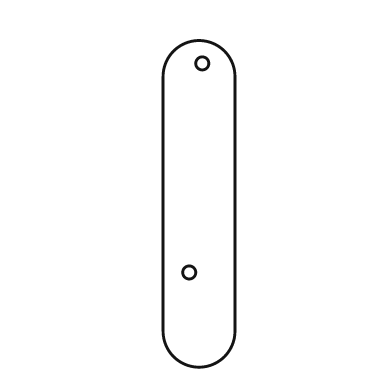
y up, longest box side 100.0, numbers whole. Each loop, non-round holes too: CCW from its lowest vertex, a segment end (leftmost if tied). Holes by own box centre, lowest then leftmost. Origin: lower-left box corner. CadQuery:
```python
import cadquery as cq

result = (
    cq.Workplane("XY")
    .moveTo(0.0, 11.0)
    .threePointArc((11.0, 0.0), (22.0, 11.0))
    .lineTo(22.0, 89.0)
    .threePointArc((11.0, 100.0), (0.0, 89.0))
    .close()
    .moveTo(8.0, 29.0)
    .circle(2.0)
    .moveTo(12.0, 93.0)
    .circle(2.0)
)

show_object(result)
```